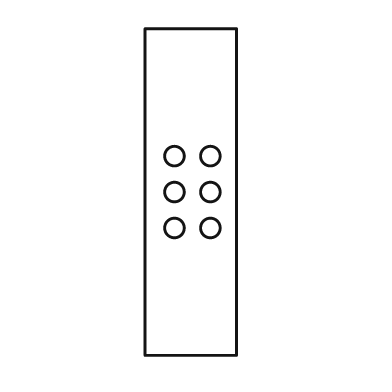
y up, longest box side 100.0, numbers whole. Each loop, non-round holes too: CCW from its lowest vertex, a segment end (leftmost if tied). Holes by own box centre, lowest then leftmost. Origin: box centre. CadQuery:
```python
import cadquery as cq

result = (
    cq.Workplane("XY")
    .moveTo(-14.0, -50.0)
    .lineTo(14.0, -50.0)
    .lineTo(14.0, 50.0)
    .lineTo(-14.0, 50.0)
    .close()
    .moveTo(-5.0, -11.0)
    .circle(3.0)
    .moveTo(6.0, -11.0)
    .circle(3.0)
    .moveTo(-5.0, 0.0)
    .circle(3.0)
    .moveTo(6.0, 0.0)
    .circle(3.0)
    .moveTo(-5.0, 11.0)
    .circle(3.0)
    .moveTo(6.0, 11.0)
    .circle(3.0)
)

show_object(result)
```